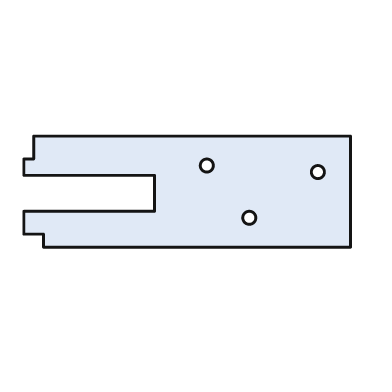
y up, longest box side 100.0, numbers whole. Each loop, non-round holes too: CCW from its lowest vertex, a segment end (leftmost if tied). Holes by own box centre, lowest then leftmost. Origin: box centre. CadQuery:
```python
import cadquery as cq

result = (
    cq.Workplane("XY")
    .moveTo(-44.0, -17.0)
    .lineTo(50.0, -17.0)
    .lineTo(50.0, 17.0)
    .lineTo(-47.0, 17.0)
    .lineTo(-47.0, 10.0)
    .lineTo(-50.0, 10.0)
    .lineTo(-50.0, 5.0)
    .lineTo(-10.0, 5.0)
    .lineTo(-10.0, -6.0)
    .lineTo(-50.0, -6.0)
    .lineTo(-50.0, -13.0)
    .lineTo(-44.0, -13.0)
    .close()
    .moveTo(19.0, -8.0)
    .circle(2.0)
    .moveTo(40.0, 6.0)
    .circle(2.0)
    .moveTo(6.0, 8.0)
    .circle(2.0)
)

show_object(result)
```